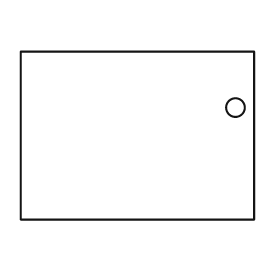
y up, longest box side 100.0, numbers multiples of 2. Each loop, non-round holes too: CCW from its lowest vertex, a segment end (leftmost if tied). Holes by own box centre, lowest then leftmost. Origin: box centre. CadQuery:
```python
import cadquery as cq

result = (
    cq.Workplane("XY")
    .moveTo(-50.0, -36.0)
    .lineTo(50.0, -36.0)
    .lineTo(50.0, 36.0)
    .lineTo(-50.0, 36.0)
    .close()
    .moveTo(42.0, 12.0)
    .circle(4.0)
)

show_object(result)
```